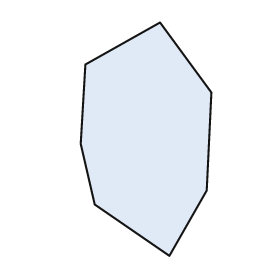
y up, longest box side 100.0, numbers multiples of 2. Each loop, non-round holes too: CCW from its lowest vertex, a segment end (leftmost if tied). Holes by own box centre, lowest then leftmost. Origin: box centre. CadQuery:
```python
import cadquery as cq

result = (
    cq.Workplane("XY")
    .moveTo(10.0, -50.0)
    .lineTo(26.0, -22.0)
    .lineTo(28.0, 20.0)
    .lineTo(6.0, 50.0)
    .lineTo(-26.0, 32.0)
    .lineTo(-28.0, -2.0)
    .lineTo(-22.0, -28.0)
    .close()
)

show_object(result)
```